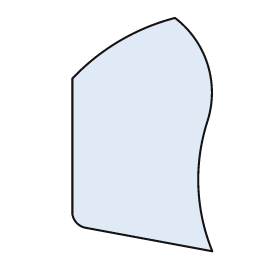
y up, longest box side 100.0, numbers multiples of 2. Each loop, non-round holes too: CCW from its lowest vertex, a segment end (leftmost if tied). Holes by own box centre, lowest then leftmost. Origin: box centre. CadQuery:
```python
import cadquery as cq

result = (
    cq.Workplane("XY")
    .moveTo(30.0, -50.0)
    .threePointArc((24.0, -22.0), (28.0, 6.0))
    .threePointArc((28.0, 30.0), (14.0, 50.0))
    .threePointArc((-10.0, 40.0), (-30.0, 24.0))
    .lineTo(-30.0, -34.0)
    .threePointArc((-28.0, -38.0), (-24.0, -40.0))
    .close()
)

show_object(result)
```